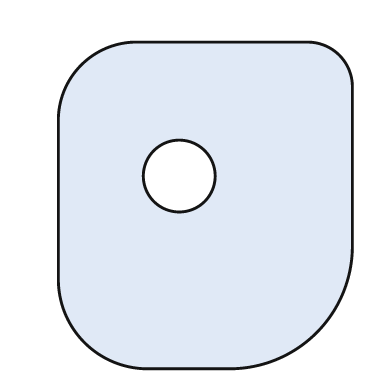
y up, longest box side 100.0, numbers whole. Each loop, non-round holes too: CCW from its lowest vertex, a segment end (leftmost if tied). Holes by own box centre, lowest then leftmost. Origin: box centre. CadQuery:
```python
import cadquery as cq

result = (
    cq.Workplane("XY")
    .moveTo(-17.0, -50.0)
    .lineTo(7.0, -50.0)
    .threePointArc((34.0, -39.0), (45.0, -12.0))
    .lineTo(45.0, 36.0)
    .threePointArc((41.0, 46.0), (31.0, 50.0))
    .lineTo(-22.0, 50.0)
    .threePointArc((-38.0, 43.0), (-45.0, 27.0))
    .lineTo(-45.0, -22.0)
    .threePointArc((-37.0, -42.0), (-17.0, -50.0))
    .close()
    .moveTo(-8.0, 9.0)
    .circle(11.0)
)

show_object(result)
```